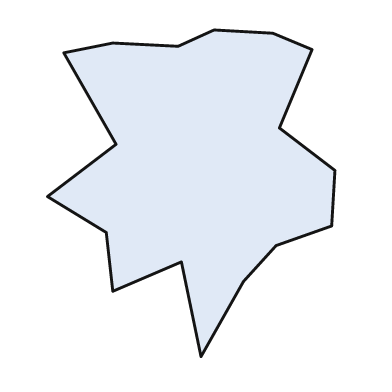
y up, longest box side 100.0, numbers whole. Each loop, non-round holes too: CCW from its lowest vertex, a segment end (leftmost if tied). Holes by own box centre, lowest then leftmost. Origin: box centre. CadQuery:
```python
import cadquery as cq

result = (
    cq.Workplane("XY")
    .moveTo(3.0, -50.0)
    .lineTo(16.0, -27.0)
    .lineTo(26.0, -16.0)
    .lineTo(43.0, -10.0)
    .lineTo(44.0, 7.0)
    .lineTo(27.0, 20.0)
    .lineTo(37.0, 44.0)
    .lineTo(25.0, 49.0)
    .lineTo(7.0, 50.0)
    .lineTo(-4.0, 45.0)
    .lineTo(-24.0, 46.0)
    .lineTo(-39.0, 43.0)
    .lineTo(-23.0, 15.0)
    .lineTo(-44.0, -1.0)
    .lineTo(-26.0, -12.0)
    .lineTo(-24.0, -30.0)
    .lineTo(-3.0, -21.0)
    .close()
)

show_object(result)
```